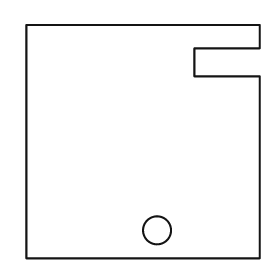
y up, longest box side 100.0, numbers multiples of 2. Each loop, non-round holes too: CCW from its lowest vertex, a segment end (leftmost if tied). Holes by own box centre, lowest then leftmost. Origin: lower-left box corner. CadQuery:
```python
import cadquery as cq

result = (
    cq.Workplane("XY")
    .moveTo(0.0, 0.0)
    .lineTo(100.0, 0.0)
    .lineTo(100.0, 78.0)
    .lineTo(72.0, 78.0)
    .lineTo(72.0, 90.0)
    .lineTo(100.0, 90.0)
    .lineTo(100.0, 100.0)
    .lineTo(0.0, 100.0)
    .close()
    .moveTo(56.0, 12.0)
    .circle(6.0)
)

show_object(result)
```